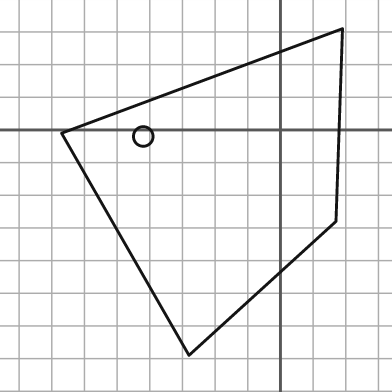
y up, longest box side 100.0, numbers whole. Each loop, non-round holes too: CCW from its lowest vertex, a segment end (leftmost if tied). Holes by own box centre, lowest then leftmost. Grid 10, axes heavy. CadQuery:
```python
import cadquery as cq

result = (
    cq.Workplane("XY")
    .moveTo(-28.0, -69.0)
    .lineTo(17.0, -28.0)
    .lineTo(19.0, 31.0)
    .lineTo(-67.0, -1.0)
    .close()
    .moveTo(-42.0, -2.0)
    .circle(3.0)
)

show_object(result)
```